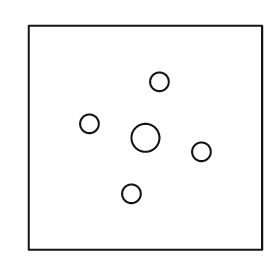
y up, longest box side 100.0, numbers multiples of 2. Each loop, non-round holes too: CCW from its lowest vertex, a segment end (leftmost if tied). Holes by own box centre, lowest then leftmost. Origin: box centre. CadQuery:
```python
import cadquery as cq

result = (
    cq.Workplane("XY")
    .moveTo(-50.0, -48.0)
    .lineTo(50.0, -48.0)
    .lineTo(50.0, 48.0)
    .lineTo(-50.0, 48.0)
    .close()
    .moveTo(-6.0, -24.0)
    .circle(4.0)
    .moveTo(24.0, -6.0)
    .circle(4.0)
    .moveTo(0.0, 0.0)
    .circle(6.0)
    .moveTo(-24.0, 6.0)
    .circle(4.0)
    .moveTo(6.0, 24.0)
    .circle(4.0)
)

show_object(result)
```